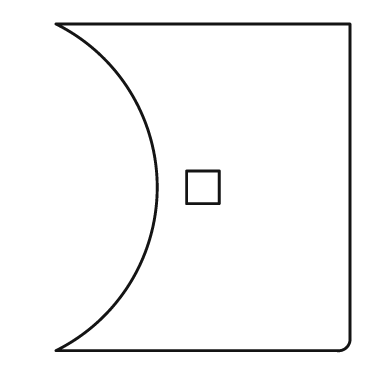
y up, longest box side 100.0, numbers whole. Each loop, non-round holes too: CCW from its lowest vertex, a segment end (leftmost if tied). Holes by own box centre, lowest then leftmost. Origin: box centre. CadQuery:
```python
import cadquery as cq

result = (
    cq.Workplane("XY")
    .moveTo(-45.0, -50.0)
    .lineTo(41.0, -50.0)
    .threePointArc((44.0, -49.0), (45.0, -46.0))
    .lineTo(45.0, 50.0)
    .lineTo(-45.0, 50.0)
    .threePointArc((-14.0, 0.0), (-45.0, -50.0))
    .close()
    .moveTo(-5.0, -5.0)
    .lineTo(5.0, -5.0)
    .lineTo(5.0, 5.0)
    .lineTo(-5.0, 5.0)
    .close()
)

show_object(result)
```